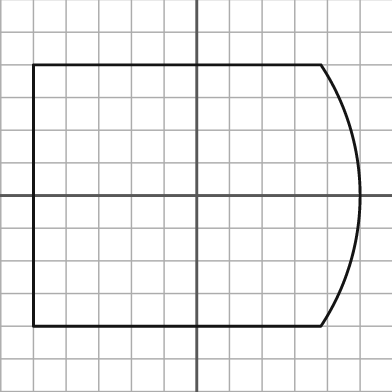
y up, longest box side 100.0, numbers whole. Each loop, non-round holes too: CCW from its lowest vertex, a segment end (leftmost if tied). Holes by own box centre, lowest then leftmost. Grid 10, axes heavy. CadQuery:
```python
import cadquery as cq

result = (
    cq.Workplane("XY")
    .moveTo(-50.0, -40.0)
    .lineTo(38.0, -40.0)
    .threePointArc((50.0, 0.0), (38.0, 40.0))
    .lineTo(-50.0, 40.0)
    .close()
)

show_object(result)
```